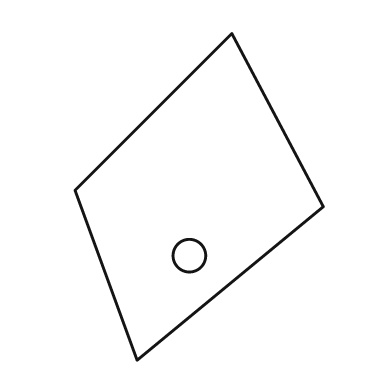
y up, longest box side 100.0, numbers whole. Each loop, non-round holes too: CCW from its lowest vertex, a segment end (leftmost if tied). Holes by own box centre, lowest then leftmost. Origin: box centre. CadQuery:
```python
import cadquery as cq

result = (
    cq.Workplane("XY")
    .moveTo(-19.0, -50.0)
    .lineTo(38.0, -3.0)
    .lineTo(10.0, 50.0)
    .lineTo(-38.0, 2.0)
    .close()
    .moveTo(-3.0, -18.0)
    .circle(5.0)
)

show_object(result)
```